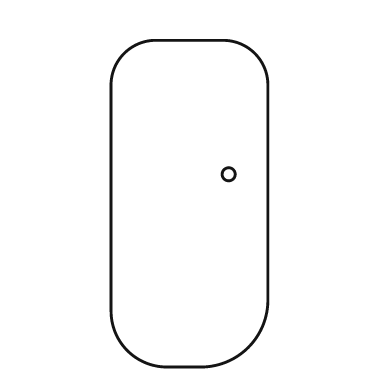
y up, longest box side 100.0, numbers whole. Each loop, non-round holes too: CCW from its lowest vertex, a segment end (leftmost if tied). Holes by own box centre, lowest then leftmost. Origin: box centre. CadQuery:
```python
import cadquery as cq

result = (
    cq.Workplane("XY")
    .moveTo(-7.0, -50.0)
    .lineTo(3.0, -50.0)
    .threePointArc((18.0, -44.0), (24.0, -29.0))
    .lineTo(24.0, 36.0)
    .threePointArc((20.0, 46.0), (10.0, 50.0))
    .lineTo(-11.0, 50.0)
    .threePointArc((-20.0, 46.0), (-24.0, 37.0))
    .lineTo(-24.0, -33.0)
    .threePointArc((-19.0, -45.0), (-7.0, -50.0))
    .close()
    .moveTo(12.0, 9.0)
    .circle(2.0)
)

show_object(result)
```